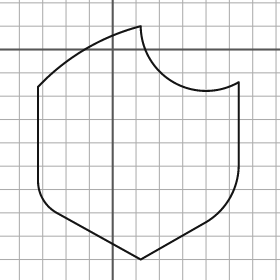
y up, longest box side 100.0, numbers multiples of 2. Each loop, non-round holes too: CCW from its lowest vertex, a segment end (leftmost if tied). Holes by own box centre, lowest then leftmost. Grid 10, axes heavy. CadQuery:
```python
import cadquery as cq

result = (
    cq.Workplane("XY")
    .moveTo(12.0, -90.0)
    .lineTo(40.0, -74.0)
    .threePointArc((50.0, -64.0), (54.0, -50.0))
    .lineTo(54.0, -14.0)
    .threePointArc((26.0, -14.0), (12.0, 10.0))
    .threePointArc((-12.0, 0.0), (-32.0, -16.0))
    .lineTo(-32.0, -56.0)
    .threePointArc((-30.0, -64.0), (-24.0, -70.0))
    .close()
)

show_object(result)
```